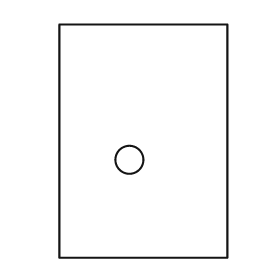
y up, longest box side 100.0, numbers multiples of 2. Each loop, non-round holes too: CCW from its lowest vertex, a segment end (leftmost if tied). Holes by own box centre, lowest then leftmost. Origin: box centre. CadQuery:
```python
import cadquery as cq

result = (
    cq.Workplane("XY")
    .moveTo(-36.0, -50.0)
    .lineTo(36.0, -50.0)
    .lineTo(36.0, 50.0)
    .lineTo(-36.0, 50.0)
    .close()
    .moveTo(-6.0, -8.0)
    .circle(6.0)
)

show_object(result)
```